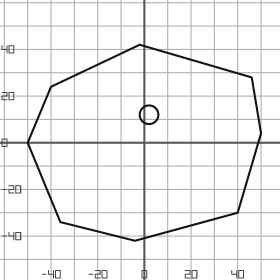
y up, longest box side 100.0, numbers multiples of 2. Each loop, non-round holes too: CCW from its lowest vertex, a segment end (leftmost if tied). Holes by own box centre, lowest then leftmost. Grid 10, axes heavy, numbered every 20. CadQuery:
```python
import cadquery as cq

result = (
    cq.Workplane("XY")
    .moveTo(-4.0, -42.0)
    .lineTo(40.0, -30.0)
    .lineTo(50.0, 4.0)
    .lineTo(46.0, 28.0)
    .lineTo(-2.0, 42.0)
    .lineTo(-40.0, 24.0)
    .lineTo(-50.0, 0.0)
    .lineTo(-36.0, -34.0)
    .close()
    .moveTo(2.0, 12.0)
    .circle(4.0)
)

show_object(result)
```